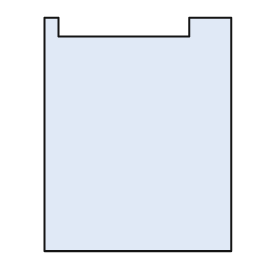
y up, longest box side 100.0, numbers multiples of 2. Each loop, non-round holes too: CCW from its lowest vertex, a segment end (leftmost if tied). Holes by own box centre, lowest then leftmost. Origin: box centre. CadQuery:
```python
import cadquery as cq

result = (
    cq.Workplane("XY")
    .moveTo(-40.0, -50.0)
    .lineTo(40.0, -50.0)
    .lineTo(40.0, 50.0)
    .lineTo(22.0, 50.0)
    .lineTo(22.0, 42.0)
    .lineTo(-34.0, 42.0)
    .lineTo(-34.0, 50.0)
    .lineTo(-40.0, 50.0)
    .close()
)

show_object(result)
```